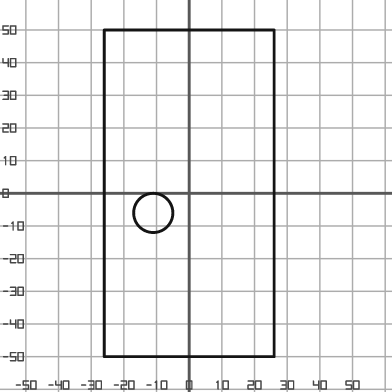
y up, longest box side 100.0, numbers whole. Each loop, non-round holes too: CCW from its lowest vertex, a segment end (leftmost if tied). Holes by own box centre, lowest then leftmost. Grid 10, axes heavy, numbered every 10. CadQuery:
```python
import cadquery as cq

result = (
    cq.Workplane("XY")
    .moveTo(-26.0, -50.0)
    .lineTo(26.0, -50.0)
    .lineTo(26.0, 50.0)
    .lineTo(-26.0, 50.0)
    .close()
    .moveTo(-11.0, -6.0)
    .circle(6.0)
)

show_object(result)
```